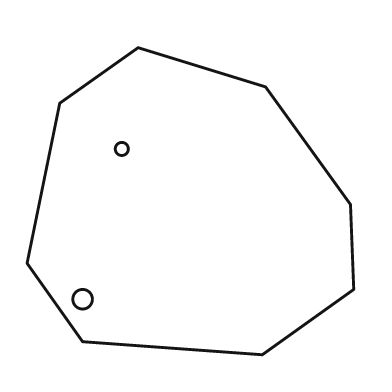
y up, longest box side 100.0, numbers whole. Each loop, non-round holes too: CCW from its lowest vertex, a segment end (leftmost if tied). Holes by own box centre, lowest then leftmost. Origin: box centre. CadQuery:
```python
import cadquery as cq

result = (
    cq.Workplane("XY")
    .moveTo(22.0, -47.0)
    .lineTo(50.0, -27.0)
    .lineTo(49.0, -1.0)
    .lineTo(23.0, 35.0)
    .lineTo(-16.0, 47.0)
    .lineTo(-40.0, 30.0)
    .lineTo(-50.0, -19.0)
    .lineTo(-33.0, -43.0)
    .close()
    .moveTo(-33.0, -30.0)
    .circle(3.0)
    .moveTo(-21.0, 16.0)
    .circle(2.0)
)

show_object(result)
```